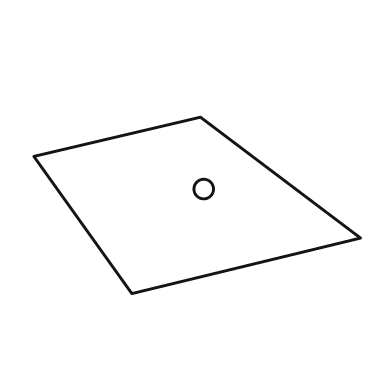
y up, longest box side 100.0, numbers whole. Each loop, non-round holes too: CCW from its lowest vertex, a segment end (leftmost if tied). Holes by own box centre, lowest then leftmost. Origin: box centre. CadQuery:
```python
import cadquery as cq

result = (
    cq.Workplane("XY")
    .moveTo(-20.0, -27.0)
    .lineTo(50.0, -10.0)
    .lineTo(1.0, 27.0)
    .lineTo(-50.0, 15.0)
    .close()
    .moveTo(2.0, 5.0)
    .circle(3.0)
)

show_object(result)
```